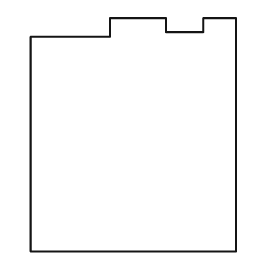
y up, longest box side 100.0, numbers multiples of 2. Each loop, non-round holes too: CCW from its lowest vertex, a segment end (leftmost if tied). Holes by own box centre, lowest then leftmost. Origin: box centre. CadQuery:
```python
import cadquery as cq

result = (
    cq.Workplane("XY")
    .moveTo(-44.0, -50.0)
    .lineTo(44.0, -50.0)
    .lineTo(44.0, 50.0)
    .lineTo(30.0, 50.0)
    .lineTo(30.0, 44.0)
    .lineTo(14.0, 44.0)
    .lineTo(14.0, 50.0)
    .lineTo(-10.0, 50.0)
    .lineTo(-10.0, 42.0)
    .lineTo(-44.0, 42.0)
    .close()
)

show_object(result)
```